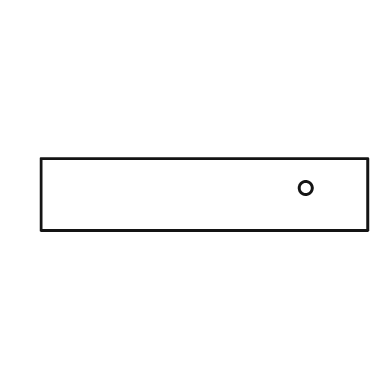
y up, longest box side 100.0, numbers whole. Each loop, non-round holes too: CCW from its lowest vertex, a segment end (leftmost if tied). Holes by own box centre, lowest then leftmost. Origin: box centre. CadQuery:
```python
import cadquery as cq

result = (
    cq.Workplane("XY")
    .moveTo(-50.0, -11.0)
    .lineTo(50.0, -11.0)
    .lineTo(50.0, 11.0)
    .lineTo(-50.0, 11.0)
    .close()
    .moveTo(31.0, 2.0)
    .circle(2.0)
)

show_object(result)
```